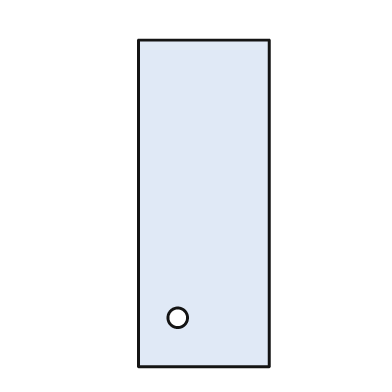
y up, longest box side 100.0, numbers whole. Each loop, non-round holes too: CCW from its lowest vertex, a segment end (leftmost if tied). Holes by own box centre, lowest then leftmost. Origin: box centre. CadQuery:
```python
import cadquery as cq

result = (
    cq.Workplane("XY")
    .moveTo(-20.0, -50.0)
    .lineTo(20.0, -50.0)
    .lineTo(20.0, 50.0)
    .lineTo(-20.0, 50.0)
    .close()
    .moveTo(-8.0, -35.0)
    .circle(3.0)
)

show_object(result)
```